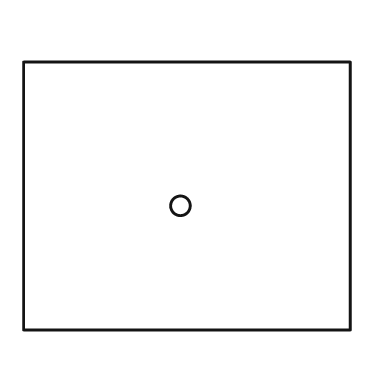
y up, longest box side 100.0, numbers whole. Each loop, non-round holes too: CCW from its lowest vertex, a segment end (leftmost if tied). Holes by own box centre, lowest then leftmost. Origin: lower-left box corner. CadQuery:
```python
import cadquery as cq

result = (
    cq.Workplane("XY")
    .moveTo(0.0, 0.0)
    .lineTo(100.0, 0.0)
    .lineTo(100.0, 82.0)
    .lineTo(0.0, 82.0)
    .close()
    .moveTo(48.0, 38.0)
    .circle(3.0)
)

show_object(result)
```